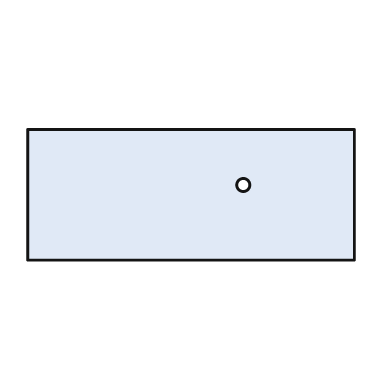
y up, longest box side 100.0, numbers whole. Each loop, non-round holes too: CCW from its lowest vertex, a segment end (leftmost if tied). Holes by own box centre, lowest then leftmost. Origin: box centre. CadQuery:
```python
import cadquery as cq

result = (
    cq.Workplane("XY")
    .moveTo(-50.0, -20.0)
    .lineTo(50.0, -20.0)
    .lineTo(50.0, 20.0)
    .lineTo(-50.0, 20.0)
    .close()
    .moveTo(16.0, 3.0)
    .circle(2.0)
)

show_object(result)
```